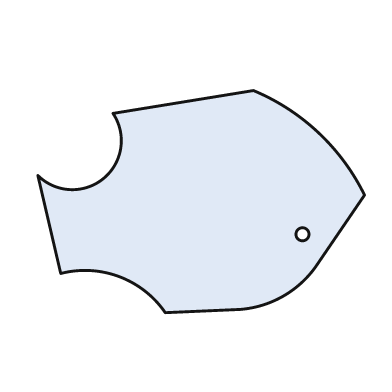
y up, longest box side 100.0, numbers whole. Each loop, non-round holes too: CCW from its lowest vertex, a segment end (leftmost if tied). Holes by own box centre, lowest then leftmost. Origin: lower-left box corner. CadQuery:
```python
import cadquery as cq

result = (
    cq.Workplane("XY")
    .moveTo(39.0, 0.0)
    .lineTo(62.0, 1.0)
    .threePointArc((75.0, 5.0), (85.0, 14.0))
    .lineTo(100.0, 36.0)
    .threePointArc((86.0, 55.0), (66.0, 68.0))
    .lineTo(23.0, 61.0)
    .threePointArc((20.0, 41.0), (0.0, 42.0))
    .lineTo(7.0, 12.0)
    .threePointArc((25.0, 11.0), (39.0, 0.0))
    .close()
    .moveTo(81.0, 24.0)
    .circle(2.0)
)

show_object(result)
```